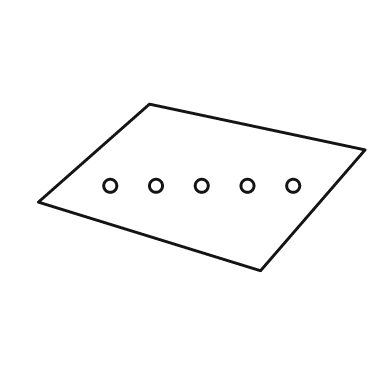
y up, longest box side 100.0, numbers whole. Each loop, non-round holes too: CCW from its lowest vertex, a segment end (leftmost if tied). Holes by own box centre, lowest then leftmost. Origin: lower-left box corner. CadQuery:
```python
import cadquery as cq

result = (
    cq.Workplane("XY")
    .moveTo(68.0, 0.0)
    .lineTo(100.0, 37.0)
    .lineTo(34.0, 51.0)
    .lineTo(0.0, 21.0)
    .close()
    .moveTo(22.0, 26.0)
    .circle(2.0)
    .moveTo(36.0, 26.0)
    .circle(2.0)
    .moveTo(50.0, 26.0)
    .circle(2.0)
    .moveTo(64.0, 26.0)
    .circle(2.0)
    .moveTo(78.0, 26.0)
    .circle(2.0)
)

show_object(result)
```